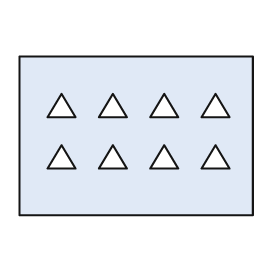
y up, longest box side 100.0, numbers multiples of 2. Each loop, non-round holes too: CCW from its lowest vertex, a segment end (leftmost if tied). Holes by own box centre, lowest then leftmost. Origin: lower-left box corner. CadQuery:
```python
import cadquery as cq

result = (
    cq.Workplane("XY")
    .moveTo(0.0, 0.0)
    .lineTo(100.0, 0.0)
    .lineTo(100.0, 68.0)
    .lineTo(0.0, 68.0)
    .close()
    .moveTo(12.0, 20.0)
    .lineTo(24.0, 20.0)
    .lineTo(18.0, 30.0)
    .close()
    .moveTo(34.0, 20.0)
    .lineTo(46.0, 20.0)
    .lineTo(40.0, 30.0)
    .close()
    .moveTo(56.0, 20.0)
    .lineTo(68.0, 20.0)
    .lineTo(62.0, 30.0)
    .close()
    .moveTo(78.0, 20.0)
    .lineTo(90.0, 20.0)
    .lineTo(84.0, 30.0)
    .close()
    .moveTo(12.0, 42.0)
    .lineTo(24.0, 42.0)
    .lineTo(18.0, 52.0)
    .close()
    .moveTo(34.0, 42.0)
    .lineTo(46.0, 42.0)
    .lineTo(40.0, 52.0)
    .close()
    .moveTo(56.0, 42.0)
    .lineTo(68.0, 42.0)
    .lineTo(62.0, 52.0)
    .close()
    .moveTo(78.0, 42.0)
    .lineTo(90.0, 42.0)
    .lineTo(84.0, 52.0)
    .close()
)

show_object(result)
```